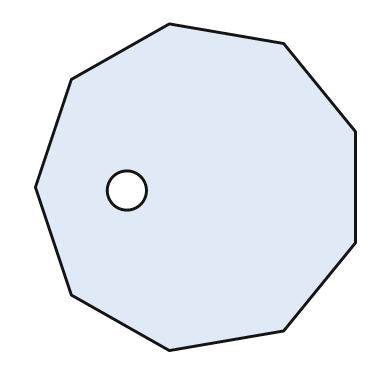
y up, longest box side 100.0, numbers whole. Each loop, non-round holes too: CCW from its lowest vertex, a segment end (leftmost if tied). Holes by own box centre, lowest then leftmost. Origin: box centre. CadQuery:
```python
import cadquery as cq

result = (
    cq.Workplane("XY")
    .moveTo(-8.0, -50.0)
    .lineTo(27.0, -44.0)
    .lineTo(49.0, -17.0)
    .lineTo(49.0, 17.0)
    .lineTo(27.0, 44.0)
    .lineTo(-8.0, 50.0)
    .lineTo(-38.0, 33.0)
    .lineTo(-49.0, 0.0)
    .lineTo(-38.0, -33.0)
    .close()
    .moveTo(-21.0, -1.0)
    .circle(6.0)
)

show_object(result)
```